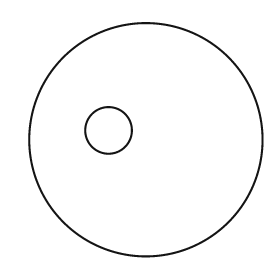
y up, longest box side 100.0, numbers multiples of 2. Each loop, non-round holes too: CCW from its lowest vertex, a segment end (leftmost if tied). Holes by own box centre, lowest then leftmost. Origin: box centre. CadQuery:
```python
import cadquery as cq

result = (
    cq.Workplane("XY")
    .moveTo(0.0, 0.0)
    .circle(50.0)
    .moveTo(-16.0, 4.0)
    .circle(10.0)
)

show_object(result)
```